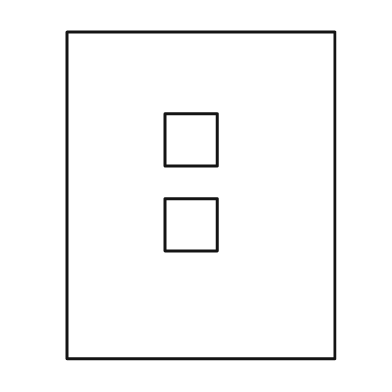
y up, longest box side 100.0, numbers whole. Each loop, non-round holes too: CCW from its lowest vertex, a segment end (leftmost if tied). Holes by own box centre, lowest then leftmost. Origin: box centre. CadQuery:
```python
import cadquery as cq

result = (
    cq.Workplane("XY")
    .moveTo(-41.0, -50.0)
    .lineTo(41.0, -50.0)
    .lineTo(41.0, 50.0)
    .lineTo(-41.0, 50.0)
    .close()
    .moveTo(-11.0, -17.0)
    .lineTo(5.0, -17.0)
    .lineTo(5.0, -1.0)
    .lineTo(-11.0, -1.0)
    .close()
    .moveTo(-11.0, 9.0)
    .lineTo(5.0, 9.0)
    .lineTo(5.0, 25.0)
    .lineTo(-11.0, 25.0)
    .close()
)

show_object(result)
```